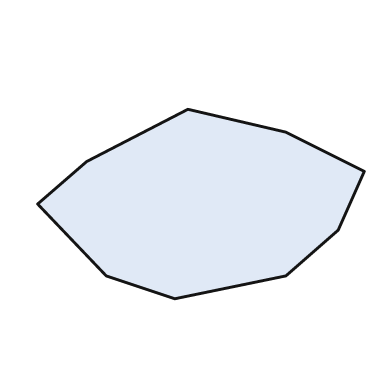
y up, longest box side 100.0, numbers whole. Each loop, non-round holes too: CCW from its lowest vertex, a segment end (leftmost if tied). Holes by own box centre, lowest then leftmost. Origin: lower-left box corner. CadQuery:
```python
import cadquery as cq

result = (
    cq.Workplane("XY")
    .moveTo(42.0, 0.0)
    .lineTo(76.0, 7.0)
    .lineTo(92.0, 21.0)
    .lineTo(100.0, 39.0)
    .lineTo(76.0, 51.0)
    .lineTo(46.0, 58.0)
    .lineTo(15.0, 42.0)
    .lineTo(0.0, 29.0)
    .lineTo(21.0, 7.0)
    .close()
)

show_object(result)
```